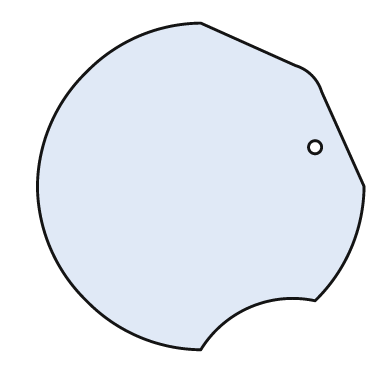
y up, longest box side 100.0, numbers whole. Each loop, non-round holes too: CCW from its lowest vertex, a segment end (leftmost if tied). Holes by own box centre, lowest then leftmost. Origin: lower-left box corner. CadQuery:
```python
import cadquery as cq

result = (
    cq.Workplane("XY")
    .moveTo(50.0, 0.0)
    .threePointArc((65.0, 13.0), (85.0, 15.0))
    .threePointArc((96.0, 31.0), (100.0, 50.0))
    .lineTo(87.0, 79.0)
    .threePointArc((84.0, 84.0), (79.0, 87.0))
    .lineTo(50.0, 100.0)
    .threePointArc((31.0, 96.0), (15.0, 85.0))
    .threePointArc((4.0, 69.0), (0.0, 50.0))
    .threePointArc((4.0, 31.0), (15.0, 15.0))
    .threePointArc((31.0, 4.0), (50.0, 0.0))
    .close()
    .moveTo(85.0, 62.0)
    .circle(2.0)
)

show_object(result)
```